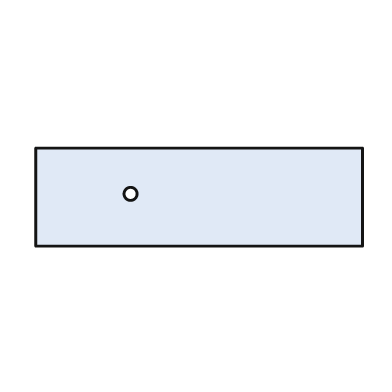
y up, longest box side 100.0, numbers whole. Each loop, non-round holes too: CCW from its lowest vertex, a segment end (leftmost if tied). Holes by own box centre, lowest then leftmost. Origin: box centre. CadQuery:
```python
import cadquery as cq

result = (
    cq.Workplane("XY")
    .moveTo(-50.0, -15.0)
    .lineTo(50.0, -15.0)
    .lineTo(50.0, 15.0)
    .lineTo(-50.0, 15.0)
    .close()
    .moveTo(-21.0, 1.0)
    .circle(2.0)
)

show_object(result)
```